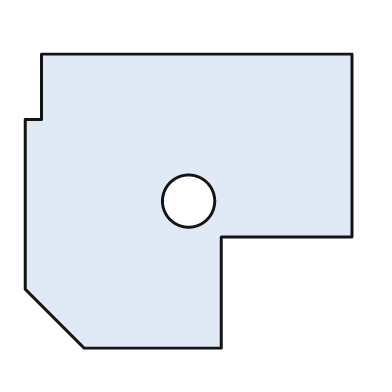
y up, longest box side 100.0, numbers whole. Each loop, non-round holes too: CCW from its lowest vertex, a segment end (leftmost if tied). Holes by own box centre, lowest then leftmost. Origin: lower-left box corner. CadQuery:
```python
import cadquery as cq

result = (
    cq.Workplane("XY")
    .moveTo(18.0, 0.0)
    .lineTo(60.0, 0.0)
    .lineTo(60.0, 34.0)
    .lineTo(100.0, 34.0)
    .lineTo(100.0, 90.0)
    .lineTo(5.0, 90.0)
    .lineTo(5.0, 70.0)
    .lineTo(0.0, 70.0)
    .lineTo(0.0, 18.0)
    .close()
    .moveTo(50.0, 45.0)
    .circle(8.0)
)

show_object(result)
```